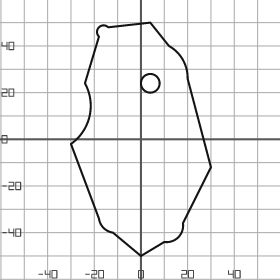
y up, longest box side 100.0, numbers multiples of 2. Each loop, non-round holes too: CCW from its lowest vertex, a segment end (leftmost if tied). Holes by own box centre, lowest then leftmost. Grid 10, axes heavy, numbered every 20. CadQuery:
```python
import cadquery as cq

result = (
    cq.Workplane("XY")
    .moveTo(0.0, -50.0)
    .lineTo(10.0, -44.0)
    .threePointArc((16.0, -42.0), (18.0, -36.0))
    .lineTo(30.0, -12.0)
    .lineTo(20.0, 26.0)
    .threePointArc((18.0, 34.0), (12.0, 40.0))
    .lineTo(4.0, 50.0)
    .lineTo(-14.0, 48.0)
    .threePointArc((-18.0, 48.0), (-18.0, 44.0))
    .lineTo(-24.0, 24.0)
    .threePointArc((-22.0, 10.0), (-30.0, -2.0))
    .lineTo(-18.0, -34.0)
    .threePointArc((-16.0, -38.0), (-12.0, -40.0))
    .close()
    .moveTo(4.0, 24.0)
    .circle(4.0)
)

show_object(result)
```